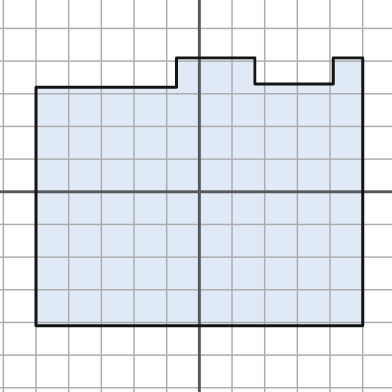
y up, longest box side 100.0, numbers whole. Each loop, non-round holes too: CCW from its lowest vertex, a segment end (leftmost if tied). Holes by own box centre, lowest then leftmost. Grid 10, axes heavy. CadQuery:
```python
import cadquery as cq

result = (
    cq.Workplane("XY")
    .moveTo(-50.0, -41.0)
    .lineTo(50.0, -41.0)
    .lineTo(50.0, 41.0)
    .lineTo(41.0, 41.0)
    .lineTo(41.0, 33.0)
    .lineTo(17.0, 33.0)
    .lineTo(17.0, 41.0)
    .lineTo(-7.0, 41.0)
    .lineTo(-7.0, 32.0)
    .lineTo(-50.0, 32.0)
    .close()
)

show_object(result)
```